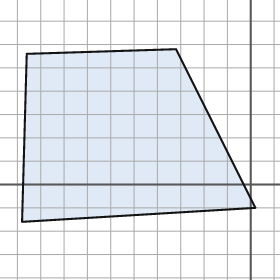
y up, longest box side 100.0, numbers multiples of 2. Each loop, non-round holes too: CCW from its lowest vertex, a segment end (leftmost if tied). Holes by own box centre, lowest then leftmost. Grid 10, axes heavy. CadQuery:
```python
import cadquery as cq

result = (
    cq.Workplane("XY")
    .moveTo(-98.0, -16.0)
    .lineTo(2.0, -10.0)
    .lineTo(-32.0, 58.0)
    .lineTo(-96.0, 56.0)
    .close()
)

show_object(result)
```